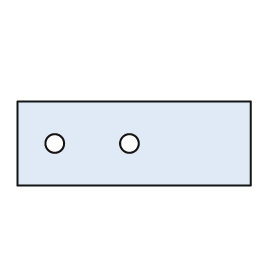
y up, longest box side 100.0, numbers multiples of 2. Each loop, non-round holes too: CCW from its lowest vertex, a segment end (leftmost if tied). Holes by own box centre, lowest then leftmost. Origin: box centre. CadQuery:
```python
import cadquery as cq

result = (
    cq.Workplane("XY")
    .moveTo(-50.0, -18.0)
    .lineTo(50.0, -18.0)
    .lineTo(50.0, 18.0)
    .lineTo(-50.0, 18.0)
    .close()
    .moveTo(-34.0, 0.0)
    .circle(4.0)
    .moveTo(-2.0, 0.0)
    .circle(4.0)
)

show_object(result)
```